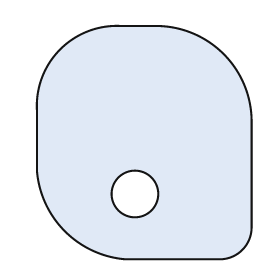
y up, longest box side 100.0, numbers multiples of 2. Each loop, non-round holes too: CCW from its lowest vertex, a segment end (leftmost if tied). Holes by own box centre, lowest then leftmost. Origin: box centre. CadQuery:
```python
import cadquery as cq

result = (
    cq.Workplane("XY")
    .moveTo(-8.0, -50.0)
    .lineTo(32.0, -50.0)
    .threePointArc((42.0, -46.0), (46.0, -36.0))
    .lineTo(46.0, 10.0)
    .threePointArc((34.0, 38.0), (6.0, 50.0))
    .lineTo(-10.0, 50.0)
    .threePointArc((-36.0, 40.0), (-46.0, 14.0))
    .lineTo(-46.0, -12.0)
    .threePointArc((-34.0, -38.0), (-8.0, -50.0))
    .close()
    .moveTo(-4.0, -22.0)
    .circle(10.0)
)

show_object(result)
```